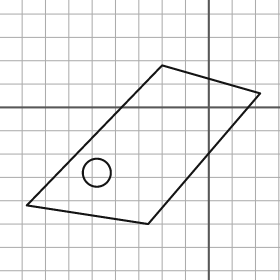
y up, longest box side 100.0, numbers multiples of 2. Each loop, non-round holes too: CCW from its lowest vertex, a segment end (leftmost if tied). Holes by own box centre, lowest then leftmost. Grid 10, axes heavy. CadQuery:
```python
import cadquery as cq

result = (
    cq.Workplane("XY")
    .moveTo(-26.0, -50.0)
    .lineTo(22.0, 6.0)
    .lineTo(-20.0, 18.0)
    .lineTo(-78.0, -42.0)
    .close()
    .moveTo(-48.0, -28.0)
    .circle(6.0)
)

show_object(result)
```